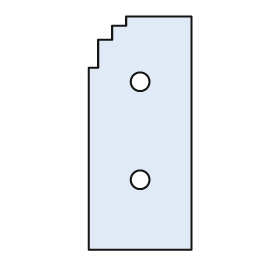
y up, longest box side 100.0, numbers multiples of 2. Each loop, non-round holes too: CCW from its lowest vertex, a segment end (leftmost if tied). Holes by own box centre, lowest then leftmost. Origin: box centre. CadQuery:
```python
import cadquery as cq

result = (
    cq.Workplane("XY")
    .moveTo(-22.0, -50.0)
    .lineTo(22.0, -50.0)
    .lineTo(22.0, 50.0)
    .lineTo(-6.0, 50.0)
    .lineTo(-6.0, 46.0)
    .lineTo(-12.0, 46.0)
    .lineTo(-12.0, 40.0)
    .lineTo(-18.0, 40.0)
    .lineTo(-18.0, 28.0)
    .lineTo(-22.0, 28.0)
    .close()
    .moveTo(0.0, -20.0)
    .circle(4.0)
    .moveTo(0.0, 22.0)
    .circle(4.0)
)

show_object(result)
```